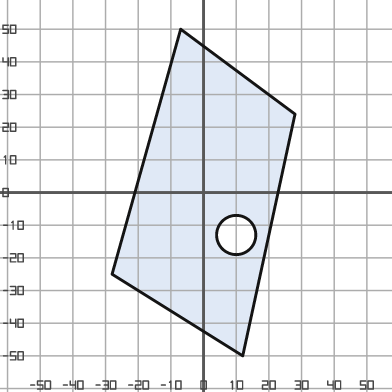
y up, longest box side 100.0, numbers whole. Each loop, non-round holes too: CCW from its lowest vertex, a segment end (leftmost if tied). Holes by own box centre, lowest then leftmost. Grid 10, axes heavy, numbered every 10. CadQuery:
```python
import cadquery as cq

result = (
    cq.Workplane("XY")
    .moveTo(12.0, -50.0)
    .lineTo(28.0, 24.0)
    .lineTo(-7.0, 50.0)
    .lineTo(-28.0, -25.0)
    .close()
    .moveTo(10.0, -13.0)
    .circle(6.0)
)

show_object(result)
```